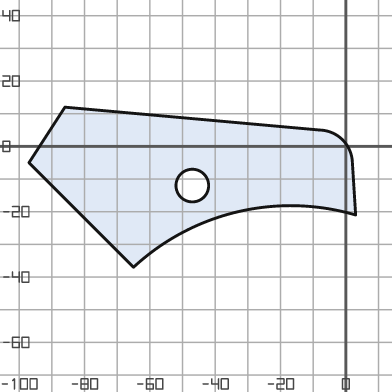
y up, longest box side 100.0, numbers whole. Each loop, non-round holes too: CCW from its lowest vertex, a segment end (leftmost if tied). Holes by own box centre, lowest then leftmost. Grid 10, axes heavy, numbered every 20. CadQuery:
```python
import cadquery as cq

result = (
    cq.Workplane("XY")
    .moveTo(-65.0, -37.0)
    .threePointArc((-33.0, -20.0), (3.0, -21.0))
    .lineTo(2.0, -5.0)
    .threePointArc((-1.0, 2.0), (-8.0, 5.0))
    .lineTo(-86.0, 12.0)
    .lineTo(-97.0, -5.0)
    .close()
    .moveTo(-47.0, -12.0)
    .circle(5.0)
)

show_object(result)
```